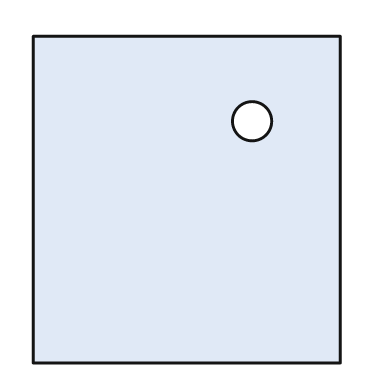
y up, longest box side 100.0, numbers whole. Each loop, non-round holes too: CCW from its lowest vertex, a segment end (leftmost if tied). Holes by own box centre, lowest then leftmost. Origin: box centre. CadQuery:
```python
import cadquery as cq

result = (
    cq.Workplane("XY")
    .moveTo(-47.0, -50.0)
    .lineTo(47.0, -50.0)
    .lineTo(47.0, 50.0)
    .lineTo(-47.0, 50.0)
    .close()
    .moveTo(20.0, 24.0)
    .circle(6.0)
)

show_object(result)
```